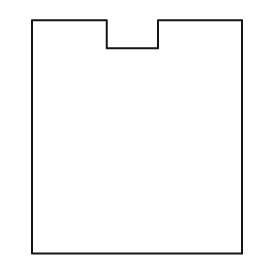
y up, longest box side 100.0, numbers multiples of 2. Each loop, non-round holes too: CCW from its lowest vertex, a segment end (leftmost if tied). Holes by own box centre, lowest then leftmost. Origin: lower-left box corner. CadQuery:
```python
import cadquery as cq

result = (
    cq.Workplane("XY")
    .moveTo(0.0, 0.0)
    .lineTo(90.0, 0.0)
    .lineTo(90.0, 100.0)
    .lineTo(54.0, 100.0)
    .lineTo(54.0, 88.0)
    .lineTo(32.0, 88.0)
    .lineTo(32.0, 100.0)
    .lineTo(0.0, 100.0)
    .close()
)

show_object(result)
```